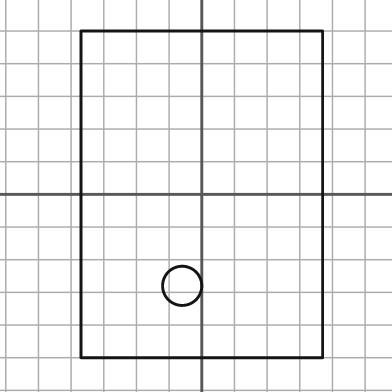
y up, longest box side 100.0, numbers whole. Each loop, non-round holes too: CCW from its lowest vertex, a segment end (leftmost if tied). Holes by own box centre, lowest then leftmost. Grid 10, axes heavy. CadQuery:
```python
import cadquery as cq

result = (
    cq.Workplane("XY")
    .moveTo(-37.0, -50.0)
    .lineTo(37.0, -50.0)
    .lineTo(37.0, 50.0)
    .lineTo(-37.0, 50.0)
    .close()
    .moveTo(-6.0, -28.0)
    .circle(6.0)
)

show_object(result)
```